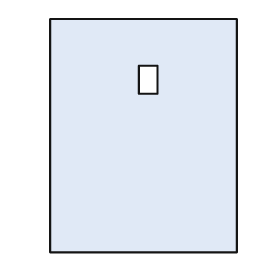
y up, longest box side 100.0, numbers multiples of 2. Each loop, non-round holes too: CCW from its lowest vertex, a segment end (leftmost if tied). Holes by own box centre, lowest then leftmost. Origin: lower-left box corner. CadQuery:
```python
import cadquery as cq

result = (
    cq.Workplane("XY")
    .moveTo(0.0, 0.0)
    .lineTo(80.0, 0.0)
    .lineTo(80.0, 100.0)
    .lineTo(0.0, 100.0)
    .close()
    .moveTo(38.0, 68.0)
    .lineTo(46.0, 68.0)
    .lineTo(46.0, 80.0)
    .lineTo(38.0, 80.0)
    .close()
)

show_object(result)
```